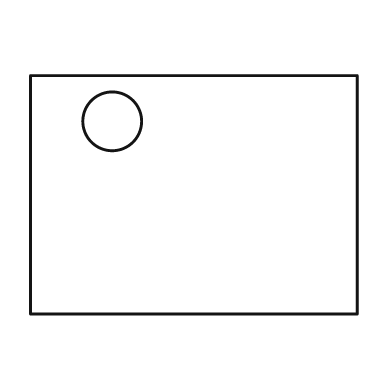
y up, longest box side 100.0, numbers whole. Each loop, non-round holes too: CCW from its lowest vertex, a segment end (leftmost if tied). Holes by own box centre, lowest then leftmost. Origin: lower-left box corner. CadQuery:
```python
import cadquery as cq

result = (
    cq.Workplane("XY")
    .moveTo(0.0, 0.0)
    .lineTo(100.0, 0.0)
    .lineTo(100.0, 73.0)
    .lineTo(0.0, 73.0)
    .close()
    .moveTo(25.0, 59.0)
    .circle(9.0)
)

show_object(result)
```